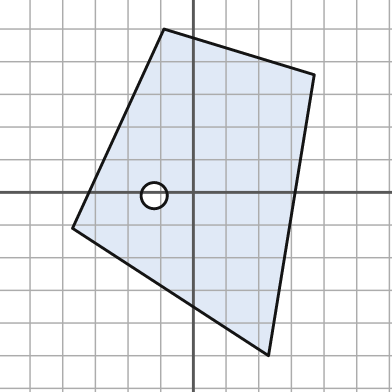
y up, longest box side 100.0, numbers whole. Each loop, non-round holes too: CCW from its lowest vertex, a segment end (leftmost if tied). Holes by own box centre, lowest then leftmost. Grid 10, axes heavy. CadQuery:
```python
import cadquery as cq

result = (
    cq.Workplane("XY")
    .moveTo(23.0, -50.0)
    .lineTo(37.0, 36.0)
    .lineTo(-9.0, 50.0)
    .lineTo(-37.0, -11.0)
    .close()
    .moveTo(-12.0, -1.0)
    .circle(4.0)
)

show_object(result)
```